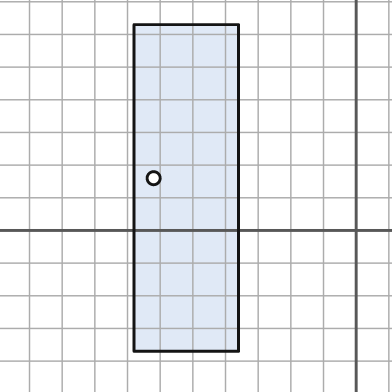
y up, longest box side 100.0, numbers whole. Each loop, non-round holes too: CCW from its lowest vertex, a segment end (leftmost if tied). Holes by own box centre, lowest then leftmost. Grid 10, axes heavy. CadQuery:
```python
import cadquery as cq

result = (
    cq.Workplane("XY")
    .moveTo(-68.0, -37.0)
    .lineTo(-36.0, -37.0)
    .lineTo(-36.0, 63.0)
    .lineTo(-68.0, 63.0)
    .close()
    .moveTo(-62.0, 16.0)
    .circle(2.0)
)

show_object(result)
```